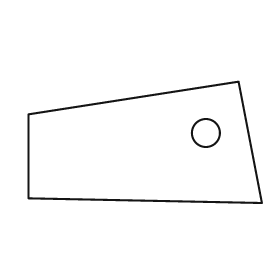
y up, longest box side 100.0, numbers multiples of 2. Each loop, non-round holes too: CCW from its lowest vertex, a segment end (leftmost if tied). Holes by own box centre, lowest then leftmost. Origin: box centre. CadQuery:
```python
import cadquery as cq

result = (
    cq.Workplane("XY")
    .moveTo(50.0, -26.0)
    .lineTo(40.0, 26.0)
    .lineTo(-50.0, 12.0)
    .lineTo(-50.0, -24.0)
    .close()
    .moveTo(26.0, 4.0)
    .circle(6.0)
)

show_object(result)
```